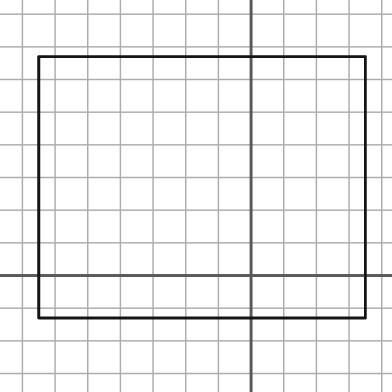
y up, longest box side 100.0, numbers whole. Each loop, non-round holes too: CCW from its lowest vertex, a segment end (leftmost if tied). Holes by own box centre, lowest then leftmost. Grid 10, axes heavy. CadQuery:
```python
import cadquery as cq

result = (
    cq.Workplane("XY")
    .moveTo(-65.0, -13.0)
    .lineTo(35.0, -13.0)
    .lineTo(35.0, 67.0)
    .lineTo(-65.0, 67.0)
    .close()
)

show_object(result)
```